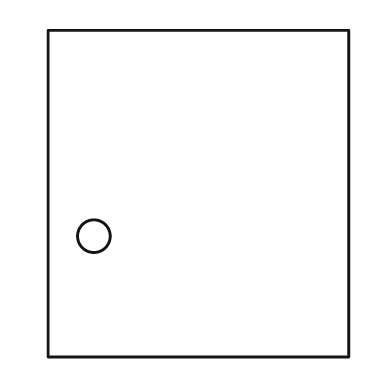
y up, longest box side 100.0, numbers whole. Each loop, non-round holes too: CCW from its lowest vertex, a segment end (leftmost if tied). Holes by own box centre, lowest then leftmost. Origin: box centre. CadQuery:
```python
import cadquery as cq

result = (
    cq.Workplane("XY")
    .moveTo(-46.0, -50.0)
    .lineTo(46.0, -50.0)
    .lineTo(46.0, 50.0)
    .lineTo(-46.0, 50.0)
    .close()
    .moveTo(-32.0, -13.0)
    .circle(5.0)
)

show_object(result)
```